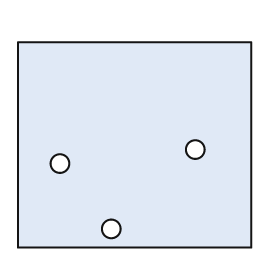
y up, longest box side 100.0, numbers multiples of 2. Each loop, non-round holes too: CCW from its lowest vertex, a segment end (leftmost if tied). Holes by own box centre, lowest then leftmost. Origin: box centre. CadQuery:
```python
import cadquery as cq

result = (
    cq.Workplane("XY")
    .moveTo(-50.0, -44.0)
    .lineTo(50.0, -44.0)
    .lineTo(50.0, 44.0)
    .lineTo(-50.0, 44.0)
    .close()
    .moveTo(-10.0, -36.0)
    .circle(4.0)
    .moveTo(-32.0, -8.0)
    .circle(4.0)
    .moveTo(26.0, -2.0)
    .circle(4.0)
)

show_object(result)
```